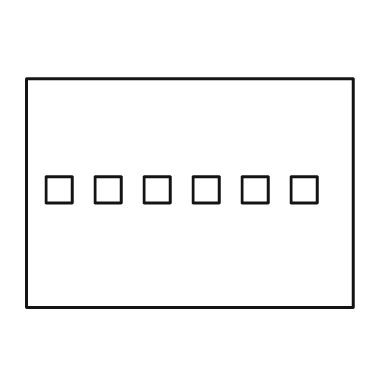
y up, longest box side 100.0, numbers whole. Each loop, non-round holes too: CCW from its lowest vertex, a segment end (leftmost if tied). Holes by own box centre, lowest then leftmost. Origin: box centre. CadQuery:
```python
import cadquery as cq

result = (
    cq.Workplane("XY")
    .moveTo(-50.0, -35.0)
    .lineTo(50.0, -35.0)
    .lineTo(50.0, 35.0)
    .lineTo(-50.0, 35.0)
    .close()
    .moveTo(-44.0, -3.0)
    .lineTo(-36.0, -3.0)
    .lineTo(-36.0, 5.0)
    .lineTo(-44.0, 5.0)
    .close()
    .moveTo(-29.0, -3.0)
    .lineTo(-21.0, -3.0)
    .lineTo(-21.0, 5.0)
    .lineTo(-29.0, 5.0)
    .close()
    .moveTo(-14.0, -3.0)
    .lineTo(-6.0, -3.0)
    .lineTo(-6.0, 5.0)
    .lineTo(-14.0, 5.0)
    .close()
    .moveTo(1.0, -3.0)
    .lineTo(9.0, -3.0)
    .lineTo(9.0, 5.0)
    .lineTo(1.0, 5.0)
    .close()
    .moveTo(16.0, -3.0)
    .lineTo(24.0, -3.0)
    .lineTo(24.0, 5.0)
    .lineTo(16.0, 5.0)
    .close()
    .moveTo(31.0, -3.0)
    .lineTo(39.0, -3.0)
    .lineTo(39.0, 5.0)
    .lineTo(31.0, 5.0)
    .close()
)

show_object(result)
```